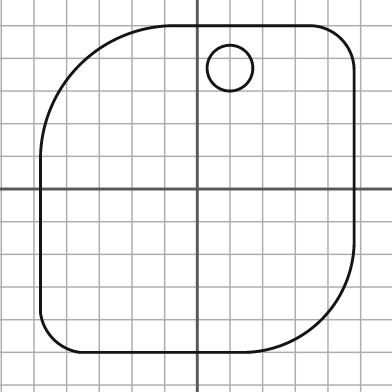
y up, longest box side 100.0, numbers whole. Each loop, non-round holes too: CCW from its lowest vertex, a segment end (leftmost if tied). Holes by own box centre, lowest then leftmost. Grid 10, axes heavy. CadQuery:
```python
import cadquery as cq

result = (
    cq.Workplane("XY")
    .moveTo(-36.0, -50.0)
    .lineTo(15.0, -50.0)
    .threePointArc((38.0, -40.0), (48.0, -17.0))
    .lineTo(48.0, 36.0)
    .threePointArc((44.0, 46.0), (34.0, 50.0))
    .lineTo(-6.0, 50.0)
    .threePointArc((-36.0, 38.0), (-48.0, 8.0))
    .lineTo(-48.0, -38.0)
    .threePointArc((-44.0, -46.0), (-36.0, -50.0))
    .close()
    .moveTo(10.0, 37.0)
    .circle(7.0)
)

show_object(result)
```